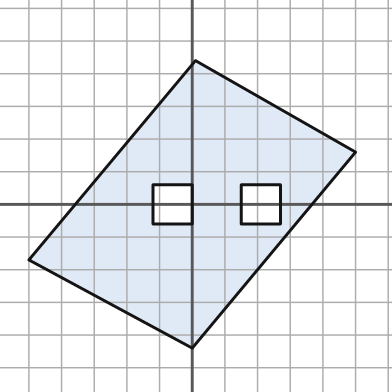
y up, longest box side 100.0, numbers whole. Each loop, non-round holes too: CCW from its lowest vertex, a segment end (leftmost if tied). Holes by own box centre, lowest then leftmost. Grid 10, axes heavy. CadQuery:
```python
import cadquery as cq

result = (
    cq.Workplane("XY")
    .moveTo(0.0, -44.0)
    .lineTo(50.0, 16.0)
    .lineTo(1.0, 44.0)
    .lineTo(-50.0, -17.0)
    .close()
    .moveTo(-12.0, -6.0)
    .lineTo(0.0, -6.0)
    .lineTo(0.0, 6.0)
    .lineTo(-12.0, 6.0)
    .close()
    .moveTo(15.0, -6.0)
    .lineTo(27.0, -6.0)
    .lineTo(27.0, 6.0)
    .lineTo(15.0, 6.0)
    .close()
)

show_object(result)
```